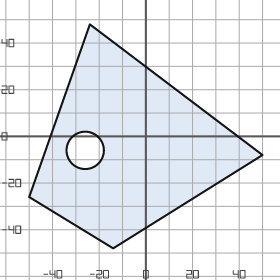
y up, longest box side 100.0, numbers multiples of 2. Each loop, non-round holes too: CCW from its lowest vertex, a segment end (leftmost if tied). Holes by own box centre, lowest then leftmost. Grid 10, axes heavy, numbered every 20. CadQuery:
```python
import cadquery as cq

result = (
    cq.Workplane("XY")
    .moveTo(-14.0, -48.0)
    .lineTo(50.0, -8.0)
    .lineTo(-24.0, 48.0)
    .lineTo(-50.0, -26.0)
    .close()
    .moveTo(-26.0, -6.0)
    .circle(8.0)
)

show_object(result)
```